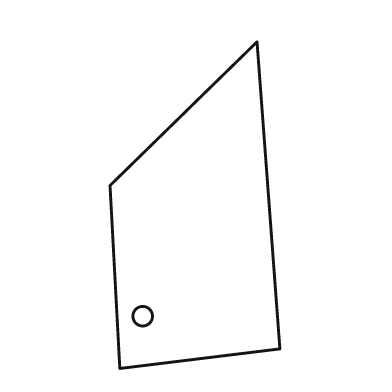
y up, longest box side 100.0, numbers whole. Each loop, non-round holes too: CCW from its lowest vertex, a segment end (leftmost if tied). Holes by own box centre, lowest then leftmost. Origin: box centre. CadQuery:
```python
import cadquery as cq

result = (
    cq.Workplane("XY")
    .moveTo(-23.0, -50.0)
    .lineTo(26.0, -44.0)
    .lineTo(19.0, 50.0)
    .lineTo(-26.0, 6.0)
    .close()
    .moveTo(-16.0, -34.0)
    .circle(3.0)
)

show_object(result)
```